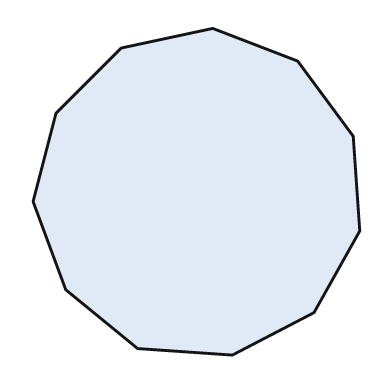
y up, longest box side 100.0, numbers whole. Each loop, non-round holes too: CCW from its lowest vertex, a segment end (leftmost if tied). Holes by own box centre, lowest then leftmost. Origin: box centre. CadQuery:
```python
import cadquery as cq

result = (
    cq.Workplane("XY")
    .moveTo(11.0, -50.0)
    .lineTo(36.0, -37.0)
    .lineTo(50.0, -12.0)
    .lineTo(48.0, 17.0)
    .lineTo(31.0, 40.0)
    .lineTo(5.0, 50.0)
    .lineTo(-23.0, 44.0)
    .lineTo(-43.0, 24.0)
    .lineTo(-50.0, -3.0)
    .lineTo(-40.0, -30.0)
    .lineTo(-18.0, -48.0)
    .close()
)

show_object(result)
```